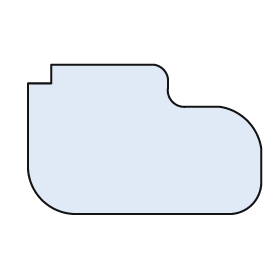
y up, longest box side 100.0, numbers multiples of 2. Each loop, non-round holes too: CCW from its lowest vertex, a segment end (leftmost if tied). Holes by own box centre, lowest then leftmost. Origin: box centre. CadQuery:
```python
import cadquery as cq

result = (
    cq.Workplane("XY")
    .moveTo(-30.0, -32.0)
    .lineTo(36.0, -32.0)
    .threePointArc((46.0, -28.0), (50.0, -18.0))
    .lineTo(50.0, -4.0)
    .threePointArc((44.0, 8.0), (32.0, 14.0))
    .lineTo(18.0, 14.0)
    .threePointArc((12.0, 16.0), (10.0, 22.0))
    .lineTo(10.0, 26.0)
    .threePointArc((8.0, 30.0), (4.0, 32.0))
    .lineTo(-40.0, 32.0)
    .lineTo(-40.0, 24.0)
    .lineTo(-50.0, 24.0)
    .lineTo(-50.0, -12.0)
    .threePointArc((-44.0, -26.0), (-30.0, -32.0))
    .close()
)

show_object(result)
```